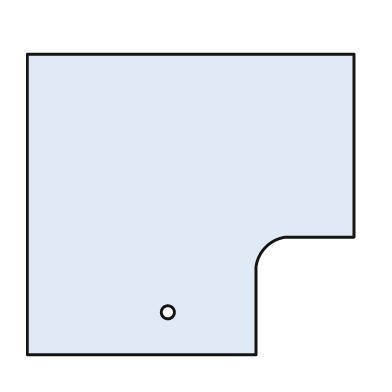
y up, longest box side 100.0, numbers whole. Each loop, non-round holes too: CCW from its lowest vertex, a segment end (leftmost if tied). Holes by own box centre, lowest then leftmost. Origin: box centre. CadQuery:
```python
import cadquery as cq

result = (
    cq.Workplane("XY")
    .moveTo(-50.0, -46.0)
    .lineTo(20.0, -46.0)
    .lineTo(20.0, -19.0)
    .threePointArc((23.0, -13.0), (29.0, -10.0))
    .lineTo(50.0, -10.0)
    .lineTo(50.0, 46.0)
    .lineTo(-50.0, 46.0)
    .close()
    .moveTo(-7.0, -33.0)
    .circle(2.0)
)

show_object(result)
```